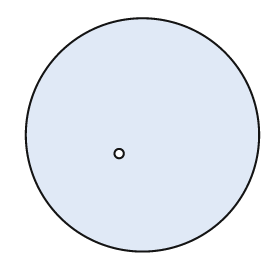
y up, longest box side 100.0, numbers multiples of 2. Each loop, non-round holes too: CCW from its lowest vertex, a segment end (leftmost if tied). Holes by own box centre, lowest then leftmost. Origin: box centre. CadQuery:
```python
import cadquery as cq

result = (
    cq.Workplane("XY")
    .moveTo(0.0, 0.0)
    .circle(50.0)
    .moveTo(-10.0, -8.0)
    .circle(2.0)
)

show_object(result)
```